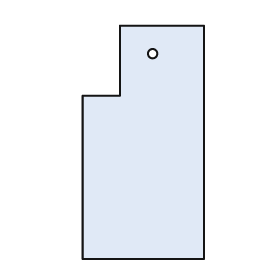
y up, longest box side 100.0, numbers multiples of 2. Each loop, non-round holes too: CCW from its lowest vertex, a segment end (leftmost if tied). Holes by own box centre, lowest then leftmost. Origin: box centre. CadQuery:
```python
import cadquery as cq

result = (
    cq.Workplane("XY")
    .moveTo(-26.0, -50.0)
    .lineTo(26.0, -50.0)
    .lineTo(26.0, 50.0)
    .lineTo(-10.0, 50.0)
    .lineTo(-10.0, 20.0)
    .lineTo(-26.0, 20.0)
    .close()
    .moveTo(4.0, 38.0)
    .circle(2.0)
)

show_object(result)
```